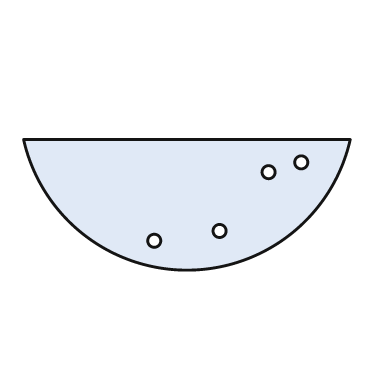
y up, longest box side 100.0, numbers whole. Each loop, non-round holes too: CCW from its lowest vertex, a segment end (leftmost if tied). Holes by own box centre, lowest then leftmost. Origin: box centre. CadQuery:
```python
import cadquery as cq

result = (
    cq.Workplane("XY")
    .moveTo(-50.0, 20.0)
    .threePointArc((0.0, -20.0), (50.0, 20.0))
    .close()
    .moveTo(-10.0, -11.0)
    .circle(2.0)
    .moveTo(10.0, -8.0)
    .circle(2.0)
    .moveTo(25.0, 10.0)
    .circle(2.0)
    .moveTo(35.0, 13.0)
    .circle(2.0)
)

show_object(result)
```